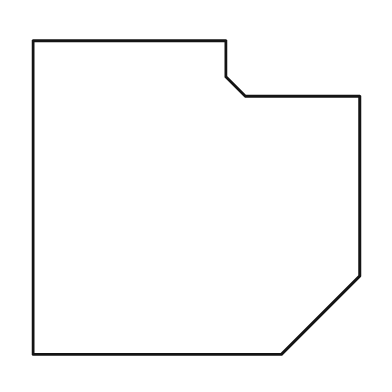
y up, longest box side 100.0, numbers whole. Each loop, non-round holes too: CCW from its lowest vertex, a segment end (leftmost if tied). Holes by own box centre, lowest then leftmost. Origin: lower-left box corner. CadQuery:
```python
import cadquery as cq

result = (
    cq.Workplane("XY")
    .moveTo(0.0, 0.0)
    .lineTo(76.0, 0.0)
    .lineTo(100.0, 24.0)
    .lineTo(100.0, 79.0)
    .lineTo(65.0, 79.0)
    .lineTo(59.0, 85.0)
    .lineTo(59.0, 96.0)
    .lineTo(0.0, 96.0)
    .close()
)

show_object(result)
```